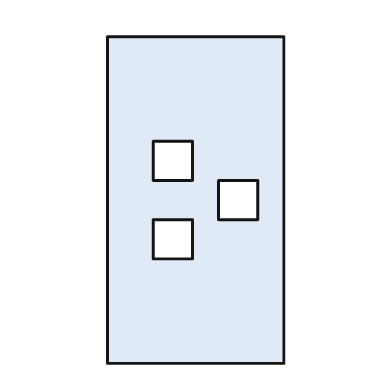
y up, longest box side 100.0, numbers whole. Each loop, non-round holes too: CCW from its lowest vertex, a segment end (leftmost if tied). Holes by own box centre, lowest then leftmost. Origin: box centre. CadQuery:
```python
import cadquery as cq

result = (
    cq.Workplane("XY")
    .moveTo(-27.0, -50.0)
    .lineTo(27.0, -50.0)
    .lineTo(27.0, 50.0)
    .lineTo(-27.0, 50.0)
    .close()
    .moveTo(-13.0, -18.0)
    .lineTo(-1.0, -18.0)
    .lineTo(-1.0, -6.0)
    .lineTo(-13.0, -6.0)
    .close()
    .moveTo(7.0, -6.0)
    .lineTo(19.0, -6.0)
    .lineTo(19.0, 6.0)
    .lineTo(7.0, 6.0)
    .close()
    .moveTo(-13.0, 6.0)
    .lineTo(-1.0, 6.0)
    .lineTo(-1.0, 18.0)
    .lineTo(-13.0, 18.0)
    .close()
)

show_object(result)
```